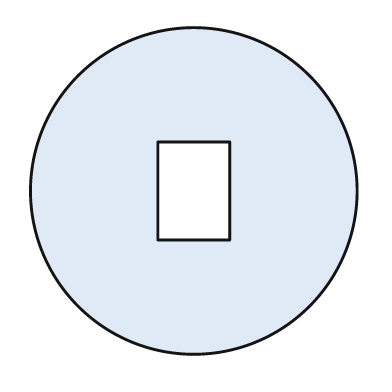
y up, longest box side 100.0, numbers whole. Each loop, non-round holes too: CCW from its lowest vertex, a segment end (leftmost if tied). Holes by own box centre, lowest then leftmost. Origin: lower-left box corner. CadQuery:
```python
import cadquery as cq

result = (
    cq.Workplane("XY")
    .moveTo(50.0, 50.0)
    .circle(50.0)
    .moveTo(39.0, 35.0)
    .lineTo(61.0, 35.0)
    .lineTo(61.0, 65.0)
    .lineTo(39.0, 65.0)
    .close()
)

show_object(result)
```